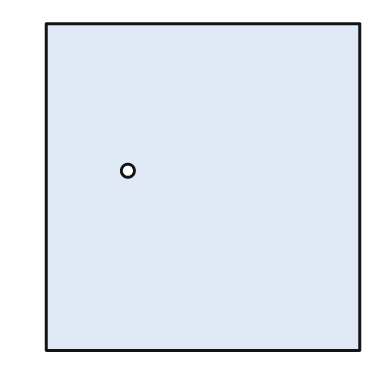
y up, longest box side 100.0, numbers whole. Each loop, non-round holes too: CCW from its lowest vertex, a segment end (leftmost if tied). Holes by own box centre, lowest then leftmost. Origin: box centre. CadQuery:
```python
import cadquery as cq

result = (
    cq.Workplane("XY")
    .moveTo(-48.0, -50.0)
    .lineTo(48.0, -50.0)
    .lineTo(48.0, 50.0)
    .lineTo(-48.0, 50.0)
    .close()
    .moveTo(-23.0, 5.0)
    .circle(2.0)
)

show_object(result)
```